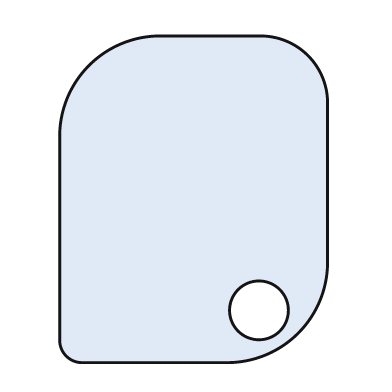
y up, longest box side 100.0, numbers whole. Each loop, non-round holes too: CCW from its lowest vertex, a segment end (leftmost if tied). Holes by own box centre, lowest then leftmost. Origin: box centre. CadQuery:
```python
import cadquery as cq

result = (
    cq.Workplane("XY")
    .moveTo(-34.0, -50.0)
    .lineTo(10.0, -50.0)
    .threePointArc((32.0, -41.0), (41.0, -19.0))
    .lineTo(41.0, 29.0)
    .threePointArc((35.0, 44.0), (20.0, 50.0))
    .lineTo(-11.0, 50.0)
    .threePointArc((-32.0, 41.0), (-41.0, 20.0))
    .lineTo(-41.0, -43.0)
    .threePointArc((-39.0, -48.0), (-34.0, -50.0))
    .close()
    .moveTo(20.0, -34.0)
    .circle(9.0)
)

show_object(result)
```